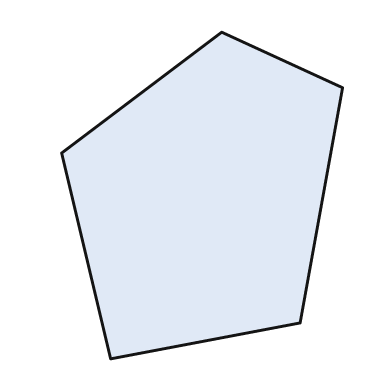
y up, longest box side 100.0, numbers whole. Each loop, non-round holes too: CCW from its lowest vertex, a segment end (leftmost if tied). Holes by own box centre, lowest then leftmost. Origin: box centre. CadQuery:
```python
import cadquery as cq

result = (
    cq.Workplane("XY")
    .moveTo(-28.0, -50.0)
    .lineTo(30.0, -39.0)
    .lineTo(43.0, 33.0)
    .lineTo(6.0, 50.0)
    .lineTo(-43.0, 13.0)
    .close()
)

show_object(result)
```